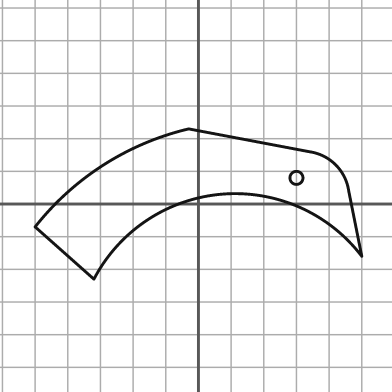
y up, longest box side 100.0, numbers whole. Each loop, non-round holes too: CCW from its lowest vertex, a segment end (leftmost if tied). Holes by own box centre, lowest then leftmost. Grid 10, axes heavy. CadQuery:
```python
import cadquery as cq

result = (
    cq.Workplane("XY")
    .moveTo(-32.0, -23.0)
    .threePointArc((7.0, 3.0), (50.0, -16.0))
    .lineTo(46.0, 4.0)
    .threePointArc((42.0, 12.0), (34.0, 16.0))
    .lineTo(-3.0, 23.0)
    .threePointArc((-29.0, 12.0), (-50.0, -7.0))
    .close()
    .moveTo(30.0, 8.0)
    .circle(2.0)
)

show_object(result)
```